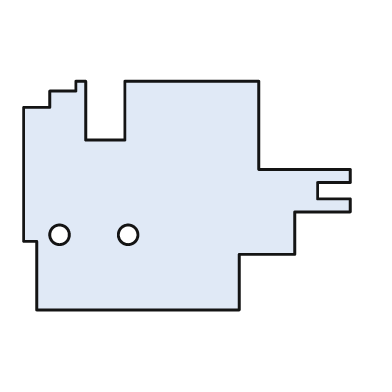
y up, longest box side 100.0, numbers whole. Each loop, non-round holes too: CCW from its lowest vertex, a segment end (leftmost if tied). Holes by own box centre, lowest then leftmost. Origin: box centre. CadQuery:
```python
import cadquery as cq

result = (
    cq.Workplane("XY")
    .moveTo(-46.0, -35.0)
    .lineTo(16.0, -35.0)
    .lineTo(16.0, -18.0)
    .lineTo(33.0, -18.0)
    .lineTo(33.0, -5.0)
    .lineTo(50.0, -5.0)
    .lineTo(50.0, -1.0)
    .lineTo(40.0, -1.0)
    .lineTo(40.0, 4.0)
    .lineTo(50.0, 4.0)
    .lineTo(50.0, 8.0)
    .lineTo(22.0, 8.0)
    .lineTo(22.0, 35.0)
    .lineTo(-19.0, 35.0)
    .lineTo(-19.0, 17.0)
    .lineTo(-31.0, 17.0)
    .lineTo(-31.0, 35.0)
    .lineTo(-34.0, 35.0)
    .lineTo(-34.0, 32.0)
    .lineTo(-42.0, 32.0)
    .lineTo(-42.0, 27.0)
    .lineTo(-50.0, 27.0)
    .lineTo(-50.0, -14.0)
    .lineTo(-46.0, -14.0)
    .close()
    .moveTo(-39.0, -12.0)
    .circle(3.0)
    .moveTo(-18.0, -12.0)
    .circle(3.0)
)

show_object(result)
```